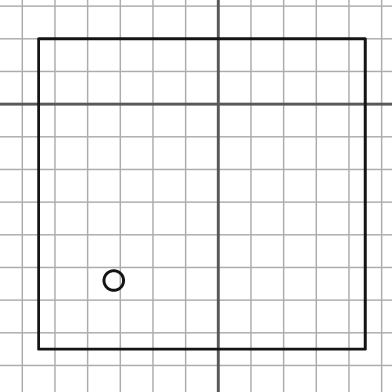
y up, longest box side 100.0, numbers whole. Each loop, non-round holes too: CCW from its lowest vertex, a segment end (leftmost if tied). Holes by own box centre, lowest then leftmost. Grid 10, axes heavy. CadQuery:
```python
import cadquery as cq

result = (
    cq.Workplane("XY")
    .moveTo(-55.0, -75.0)
    .lineTo(45.0, -75.0)
    .lineTo(45.0, 20.0)
    .lineTo(-55.0, 20.0)
    .close()
    .moveTo(-32.0, -54.0)
    .circle(3.0)
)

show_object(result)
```